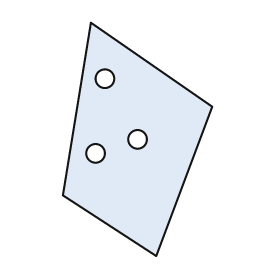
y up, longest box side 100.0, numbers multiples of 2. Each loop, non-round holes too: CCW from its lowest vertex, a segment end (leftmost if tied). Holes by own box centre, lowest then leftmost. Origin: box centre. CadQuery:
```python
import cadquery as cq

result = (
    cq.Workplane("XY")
    .moveTo(8.0, -50.0)
    .lineTo(32.0, 14.0)
    .lineTo(-20.0, 50.0)
    .lineTo(-32.0, -24.0)
    .close()
    .moveTo(-18.0, -6.0)
    .circle(4.0)
    .moveTo(0.0, 0.0)
    .circle(4.0)
    .moveTo(-14.0, 26.0)
    .circle(4.0)
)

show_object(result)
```